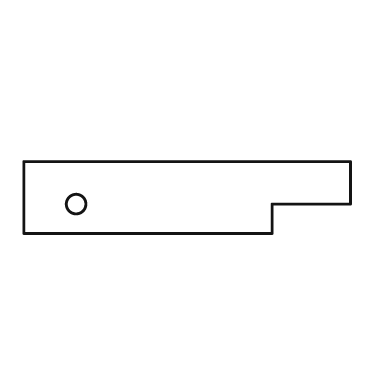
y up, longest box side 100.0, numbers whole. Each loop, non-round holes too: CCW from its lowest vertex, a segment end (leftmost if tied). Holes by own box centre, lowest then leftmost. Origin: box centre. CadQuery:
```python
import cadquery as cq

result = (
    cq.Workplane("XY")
    .moveTo(-50.0, -11.0)
    .lineTo(26.0, -11.0)
    .lineTo(26.0, -2.0)
    .lineTo(50.0, -2.0)
    .lineTo(50.0, 11.0)
    .lineTo(-50.0, 11.0)
    .close()
    .moveTo(-34.0, -2.0)
    .circle(3.0)
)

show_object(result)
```